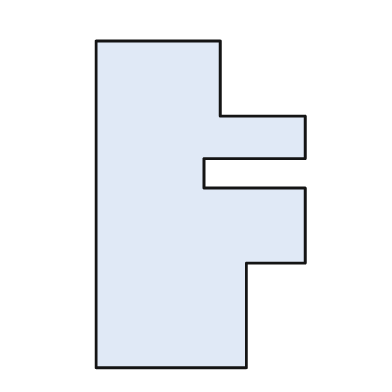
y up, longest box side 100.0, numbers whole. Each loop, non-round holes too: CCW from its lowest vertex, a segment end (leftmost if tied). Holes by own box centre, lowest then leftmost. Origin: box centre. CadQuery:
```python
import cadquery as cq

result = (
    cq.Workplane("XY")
    .moveTo(-32.0, -50.0)
    .lineTo(14.0, -50.0)
    .lineTo(14.0, -18.0)
    .lineTo(32.0, -18.0)
    .lineTo(32.0, 5.0)
    .lineTo(1.0, 5.0)
    .lineTo(1.0, 14.0)
    .lineTo(32.0, 14.0)
    .lineTo(32.0, 27.0)
    .lineTo(6.0, 27.0)
    .lineTo(6.0, 50.0)
    .lineTo(-32.0, 50.0)
    .close()
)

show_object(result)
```